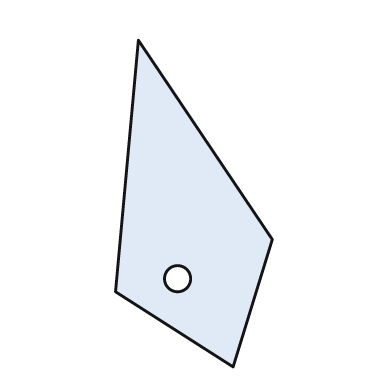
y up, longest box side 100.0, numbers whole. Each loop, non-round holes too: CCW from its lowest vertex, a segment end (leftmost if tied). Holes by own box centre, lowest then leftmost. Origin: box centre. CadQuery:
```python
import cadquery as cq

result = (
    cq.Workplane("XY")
    .moveTo(12.0, -50.0)
    .lineTo(24.0, -11.0)
    .lineTo(-17.0, 50.0)
    .lineTo(-24.0, -27.0)
    .close()
    .moveTo(-5.0, -23.0)
    .circle(4.0)
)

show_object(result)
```